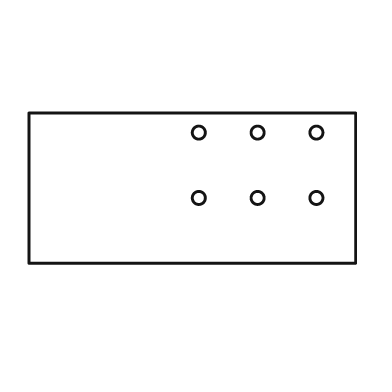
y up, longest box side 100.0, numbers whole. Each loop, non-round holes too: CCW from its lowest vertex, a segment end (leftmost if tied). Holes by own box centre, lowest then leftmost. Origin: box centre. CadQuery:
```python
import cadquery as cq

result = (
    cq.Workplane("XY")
    .moveTo(-50.0, -23.0)
    .lineTo(50.0, -23.0)
    .lineTo(50.0, 23.0)
    .lineTo(-50.0, 23.0)
    .close()
    .moveTo(2.0, -3.0)
    .circle(2.0)
    .moveTo(20.0, -3.0)
    .circle(2.0)
    .moveTo(38.0, -3.0)
    .circle(2.0)
    .moveTo(2.0, 17.0)
    .circle(2.0)
    .moveTo(20.0, 17.0)
    .circle(2.0)
    .moveTo(38.0, 17.0)
    .circle(2.0)
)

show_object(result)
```